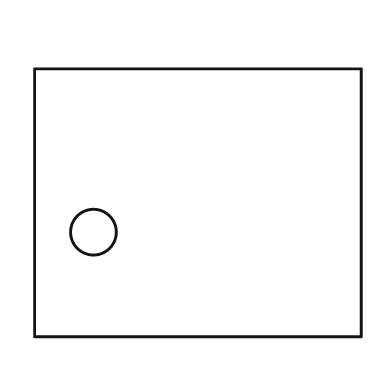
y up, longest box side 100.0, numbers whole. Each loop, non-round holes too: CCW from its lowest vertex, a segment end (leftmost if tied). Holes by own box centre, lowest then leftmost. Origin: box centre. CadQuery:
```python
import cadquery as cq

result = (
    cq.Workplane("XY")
    .moveTo(-50.0, -41.0)
    .lineTo(50.0, -41.0)
    .lineTo(50.0, 41.0)
    .lineTo(-50.0, 41.0)
    .close()
    .moveTo(-32.0, -9.0)
    .circle(7.0)
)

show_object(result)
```